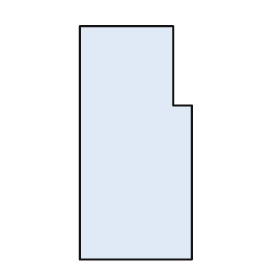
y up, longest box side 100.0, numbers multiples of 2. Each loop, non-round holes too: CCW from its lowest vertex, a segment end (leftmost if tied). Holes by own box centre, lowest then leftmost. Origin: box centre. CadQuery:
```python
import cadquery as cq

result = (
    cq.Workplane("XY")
    .moveTo(-24.0, -50.0)
    .lineTo(24.0, -50.0)
    .lineTo(24.0, 16.0)
    .lineTo(16.0, 16.0)
    .lineTo(16.0, 50.0)
    .lineTo(-24.0, 50.0)
    .close()
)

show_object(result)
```